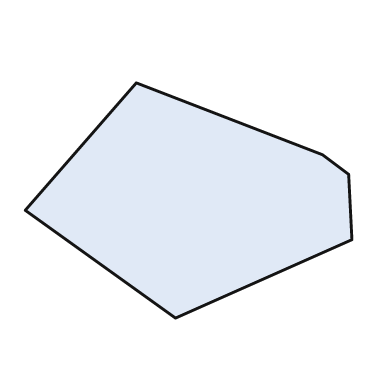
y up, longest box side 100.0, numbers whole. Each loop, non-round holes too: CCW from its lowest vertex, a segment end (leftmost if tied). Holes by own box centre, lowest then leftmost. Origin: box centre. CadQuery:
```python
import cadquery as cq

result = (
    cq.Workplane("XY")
    .moveTo(-4.0, -36.0)
    .lineTo(50.0, -12.0)
    .lineTo(49.0, 8.0)
    .lineTo(41.0, 14.0)
    .lineTo(-16.0, 36.0)
    .lineTo(-50.0, -3.0)
    .close()
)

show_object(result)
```